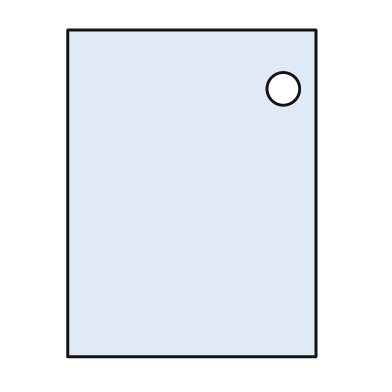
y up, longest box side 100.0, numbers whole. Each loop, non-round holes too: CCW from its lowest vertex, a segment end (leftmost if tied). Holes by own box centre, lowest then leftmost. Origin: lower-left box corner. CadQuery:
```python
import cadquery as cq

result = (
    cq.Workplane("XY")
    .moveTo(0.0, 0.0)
    .lineTo(76.0, 0.0)
    .lineTo(76.0, 100.0)
    .lineTo(0.0, 100.0)
    .close()
    .moveTo(66.0, 82.0)
    .circle(5.0)
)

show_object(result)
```